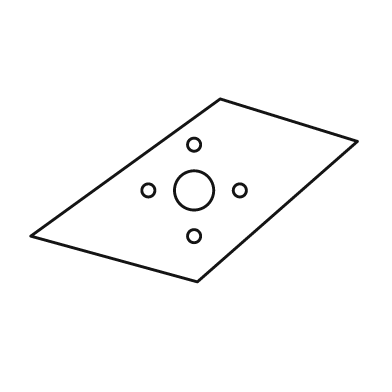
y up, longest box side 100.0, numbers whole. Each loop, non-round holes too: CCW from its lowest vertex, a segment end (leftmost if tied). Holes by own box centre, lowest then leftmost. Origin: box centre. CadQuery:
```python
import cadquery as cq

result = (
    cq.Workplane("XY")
    .moveTo(1.0, -28.0)
    .lineTo(50.0, 15.0)
    .lineTo(8.0, 28.0)
    .lineTo(-50.0, -14.0)
    .close()
    .moveTo(0.0, -14.0)
    .circle(2.0)
    .moveTo(-14.0, 0.0)
    .circle(2.0)
    .moveTo(0.0, 0.0)
    .circle(6.0)
    .moveTo(14.0, 0.0)
    .circle(2.0)
    .moveTo(0.0, 14.0)
    .circle(2.0)
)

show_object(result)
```